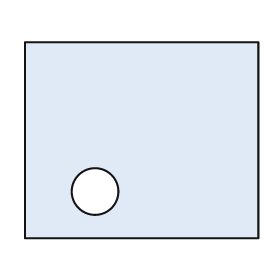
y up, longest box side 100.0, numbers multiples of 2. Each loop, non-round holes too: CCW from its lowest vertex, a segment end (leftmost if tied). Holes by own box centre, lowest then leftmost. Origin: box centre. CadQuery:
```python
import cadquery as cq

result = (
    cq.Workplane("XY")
    .moveTo(-50.0, -42.0)
    .lineTo(50.0, -42.0)
    .lineTo(50.0, 42.0)
    .lineTo(-50.0, 42.0)
    .close()
    .moveTo(-20.0, -22.0)
    .circle(10.0)
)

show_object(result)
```